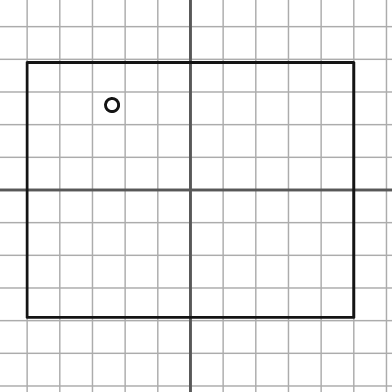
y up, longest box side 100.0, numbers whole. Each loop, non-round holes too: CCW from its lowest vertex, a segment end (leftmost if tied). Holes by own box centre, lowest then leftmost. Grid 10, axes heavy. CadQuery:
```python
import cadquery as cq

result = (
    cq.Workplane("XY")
    .moveTo(-50.0, -39.0)
    .lineTo(50.0, -39.0)
    .lineTo(50.0, 39.0)
    .lineTo(-50.0, 39.0)
    .close()
    .moveTo(-24.0, 26.0)
    .circle(2.0)
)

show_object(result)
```